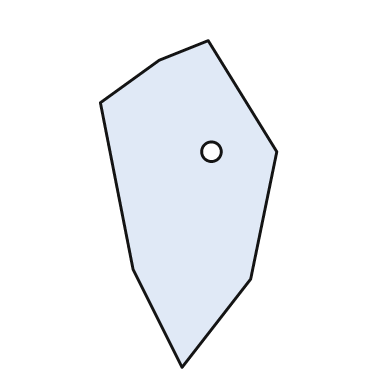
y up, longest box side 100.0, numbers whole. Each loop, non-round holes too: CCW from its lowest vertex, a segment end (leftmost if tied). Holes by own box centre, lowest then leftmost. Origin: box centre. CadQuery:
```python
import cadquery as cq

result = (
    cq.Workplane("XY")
    .moveTo(-2.0, -50.0)
    .lineTo(19.0, -23.0)
    .lineTo(27.0, 16.0)
    .lineTo(6.0, 50.0)
    .lineTo(-9.0, 44.0)
    .lineTo(-27.0, 31.0)
    .lineTo(-17.0, -20.0)
    .close()
    .moveTo(7.0, 16.0)
    .circle(3.0)
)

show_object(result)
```